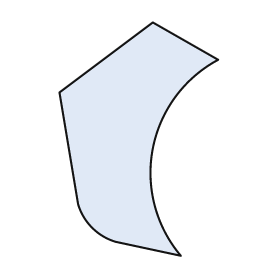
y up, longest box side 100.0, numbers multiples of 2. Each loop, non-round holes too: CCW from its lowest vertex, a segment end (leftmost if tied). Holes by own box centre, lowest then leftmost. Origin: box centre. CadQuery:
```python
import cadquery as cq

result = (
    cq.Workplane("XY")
    .moveTo(18.0, -50.0)
    .threePointArc((6.0, -4.0), (34.0, 34.0))
    .lineTo(6.0, 50.0)
    .lineTo(-34.0, 20.0)
    .lineTo(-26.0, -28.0)
    .threePointArc((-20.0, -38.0), (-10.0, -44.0))
    .close()
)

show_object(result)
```